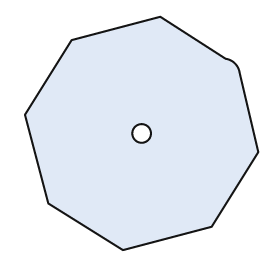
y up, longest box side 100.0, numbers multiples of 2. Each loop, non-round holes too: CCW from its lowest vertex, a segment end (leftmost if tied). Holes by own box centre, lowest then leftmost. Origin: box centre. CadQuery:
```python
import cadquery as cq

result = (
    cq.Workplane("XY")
    .moveTo(-8.0, -50.0)
    .lineTo(30.0, -40.0)
    .lineTo(50.0, -8.0)
    .lineTo(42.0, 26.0)
    .threePointArc((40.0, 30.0), (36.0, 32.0))
    .lineTo(8.0, 50.0)
    .lineTo(-30.0, 40.0)
    .lineTo(-50.0, 8.0)
    .lineTo(-40.0, -30.0)
    .close()
    .moveTo(0.0, 0.0)
    .circle(4.0)
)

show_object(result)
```